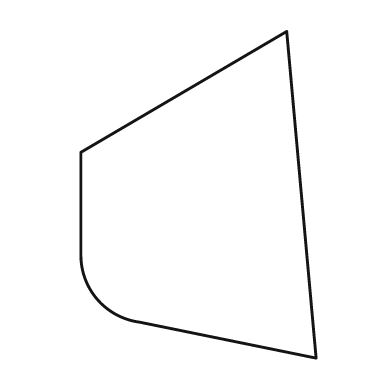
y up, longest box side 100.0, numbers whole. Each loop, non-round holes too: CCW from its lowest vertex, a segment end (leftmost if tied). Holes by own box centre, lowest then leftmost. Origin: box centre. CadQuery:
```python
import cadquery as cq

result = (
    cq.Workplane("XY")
    .moveTo(36.0, -50.0)
    .lineTo(27.0, 50.0)
    .lineTo(-36.0, 13.0)
    .lineTo(-36.0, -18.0)
    .threePointArc((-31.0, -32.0), (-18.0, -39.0))
    .close()
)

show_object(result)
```